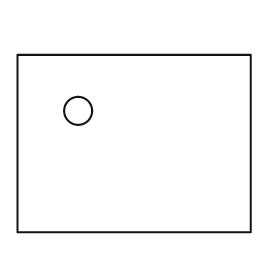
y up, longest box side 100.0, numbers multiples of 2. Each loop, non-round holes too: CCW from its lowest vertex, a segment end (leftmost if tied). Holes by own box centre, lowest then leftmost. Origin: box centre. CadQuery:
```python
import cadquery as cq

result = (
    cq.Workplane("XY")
    .moveTo(-50.0, -38.0)
    .lineTo(50.0, -38.0)
    .lineTo(50.0, 38.0)
    .lineTo(-50.0, 38.0)
    .close()
    .moveTo(-24.0, 14.0)
    .circle(6.0)
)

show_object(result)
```